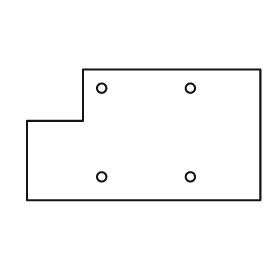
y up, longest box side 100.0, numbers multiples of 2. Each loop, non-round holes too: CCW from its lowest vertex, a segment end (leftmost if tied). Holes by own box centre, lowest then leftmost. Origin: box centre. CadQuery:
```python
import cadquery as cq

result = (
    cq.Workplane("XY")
    .moveTo(-50.0, -28.0)
    .lineTo(50.0, -28.0)
    .lineTo(50.0, 28.0)
    .lineTo(-26.0, 28.0)
    .lineTo(-26.0, 6.0)
    .lineTo(-50.0, 6.0)
    .close()
    .moveTo(-18.0, -18.0)
    .circle(2.0)
    .moveTo(20.0, -18.0)
    .circle(2.0)
    .moveTo(-18.0, 20.0)
    .circle(2.0)
    .moveTo(20.0, 20.0)
    .circle(2.0)
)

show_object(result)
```